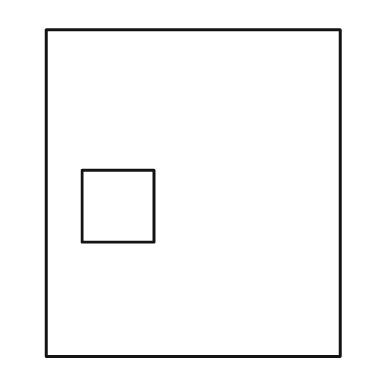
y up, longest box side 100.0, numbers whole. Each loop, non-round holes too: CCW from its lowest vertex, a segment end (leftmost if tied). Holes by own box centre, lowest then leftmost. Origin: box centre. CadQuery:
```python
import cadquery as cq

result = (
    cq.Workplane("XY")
    .moveTo(-45.0, -50.0)
    .lineTo(45.0, -50.0)
    .lineTo(45.0, 50.0)
    .lineTo(-45.0, 50.0)
    .close()
    .moveTo(-34.0, -15.0)
    .lineTo(-12.0, -15.0)
    .lineTo(-12.0, 7.0)
    .lineTo(-34.0, 7.0)
    .close()
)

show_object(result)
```